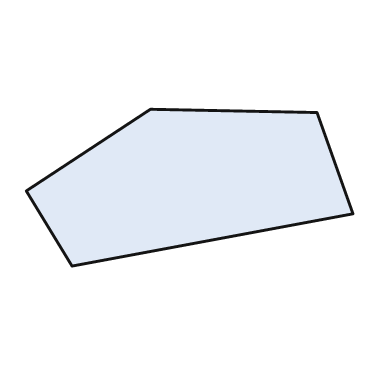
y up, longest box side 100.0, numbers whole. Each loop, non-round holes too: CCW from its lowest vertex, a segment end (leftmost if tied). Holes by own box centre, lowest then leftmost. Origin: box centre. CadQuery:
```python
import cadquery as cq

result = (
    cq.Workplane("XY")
    .moveTo(-36.0, -24.0)
    .lineTo(50.0, -8.0)
    .lineTo(39.0, 23.0)
    .lineTo(-12.0, 24.0)
    .lineTo(-50.0, -1.0)
    .close()
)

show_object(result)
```